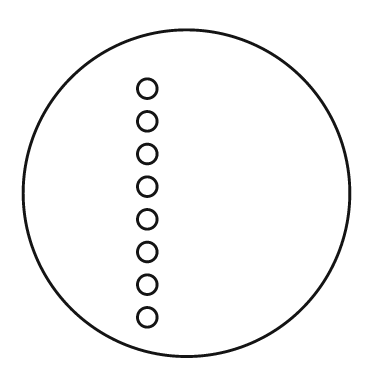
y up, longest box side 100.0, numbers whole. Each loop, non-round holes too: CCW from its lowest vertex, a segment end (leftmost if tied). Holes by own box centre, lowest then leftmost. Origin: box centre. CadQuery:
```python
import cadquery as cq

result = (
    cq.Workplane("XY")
    .moveTo(0.0, 0.0)
    .circle(50.0)
    .moveTo(-12.0, -38.0)
    .circle(3.0)
    .moveTo(-12.0, -28.0)
    .circle(3.0)
    .moveTo(-12.0, -18.0)
    .circle(3.0)
    .moveTo(-12.0, -8.0)
    .circle(3.0)
    .moveTo(-12.0, 2.0)
    .circle(3.0)
    .moveTo(-12.0, 12.0)
    .circle(3.0)
    .moveTo(-12.0, 22.0)
    .circle(3.0)
    .moveTo(-12.0, 32.0)
    .circle(3.0)
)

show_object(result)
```